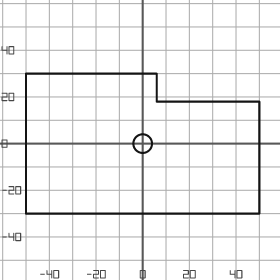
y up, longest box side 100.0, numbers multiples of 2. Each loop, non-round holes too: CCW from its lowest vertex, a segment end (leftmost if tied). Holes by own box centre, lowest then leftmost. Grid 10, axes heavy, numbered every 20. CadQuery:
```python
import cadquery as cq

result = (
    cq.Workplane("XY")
    .moveTo(-50.0, -30.0)
    .lineTo(50.0, -30.0)
    .lineTo(50.0, 18.0)
    .lineTo(6.0, 18.0)
    .lineTo(6.0, 30.0)
    .lineTo(-50.0, 30.0)
    .close()
    .moveTo(0.0, 0.0)
    .circle(4.0)
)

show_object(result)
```